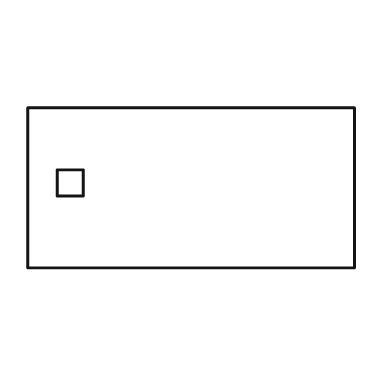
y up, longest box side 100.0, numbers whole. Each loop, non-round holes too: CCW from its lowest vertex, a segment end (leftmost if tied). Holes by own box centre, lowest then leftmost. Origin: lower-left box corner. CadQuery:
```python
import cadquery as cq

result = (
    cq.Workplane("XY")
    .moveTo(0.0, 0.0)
    .lineTo(100.0, 0.0)
    .lineTo(100.0, 49.0)
    .lineTo(0.0, 49.0)
    .close()
    .moveTo(9.0, 22.0)
    .lineTo(17.0, 22.0)
    .lineTo(17.0, 30.0)
    .lineTo(9.0, 30.0)
    .close()
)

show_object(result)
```